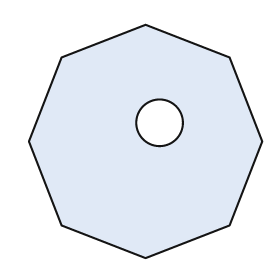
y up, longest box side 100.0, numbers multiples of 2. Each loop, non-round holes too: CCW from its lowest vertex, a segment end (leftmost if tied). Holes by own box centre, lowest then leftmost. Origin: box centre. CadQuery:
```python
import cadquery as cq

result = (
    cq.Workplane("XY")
    .moveTo(0.0, -50.0)
    .lineTo(36.0, -36.0)
    .lineTo(50.0, 0.0)
    .lineTo(36.0, 36.0)
    .lineTo(0.0, 50.0)
    .lineTo(-36.0, 36.0)
    .lineTo(-50.0, 0.0)
    .lineTo(-36.0, -36.0)
    .close()
    .moveTo(6.0, 8.0)
    .circle(10.0)
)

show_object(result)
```